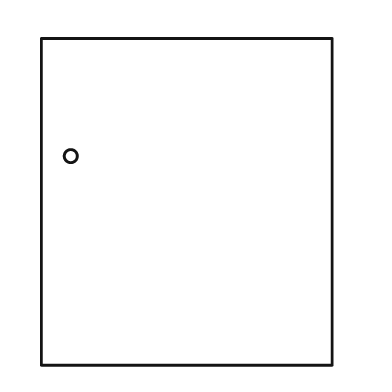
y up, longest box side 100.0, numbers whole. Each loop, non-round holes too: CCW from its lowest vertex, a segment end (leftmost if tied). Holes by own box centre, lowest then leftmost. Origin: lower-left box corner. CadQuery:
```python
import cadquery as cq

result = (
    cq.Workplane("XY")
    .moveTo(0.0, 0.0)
    .lineTo(89.0, 0.0)
    .lineTo(89.0, 100.0)
    .lineTo(0.0, 100.0)
    .close()
    .moveTo(9.0, 64.0)
    .circle(2.0)
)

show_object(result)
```